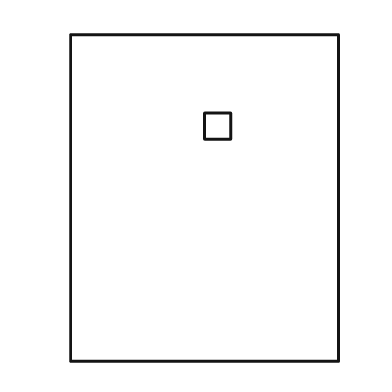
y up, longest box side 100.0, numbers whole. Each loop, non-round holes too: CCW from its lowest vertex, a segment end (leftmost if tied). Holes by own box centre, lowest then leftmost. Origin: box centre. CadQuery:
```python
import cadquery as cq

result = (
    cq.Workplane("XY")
    .moveTo(-41.0, -50.0)
    .lineTo(41.0, -50.0)
    .lineTo(41.0, 50.0)
    .lineTo(-41.0, 50.0)
    .close()
    .moveTo(0.0, 18.0)
    .lineTo(8.0, 18.0)
    .lineTo(8.0, 26.0)
    .lineTo(0.0, 26.0)
    .close()
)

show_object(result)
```